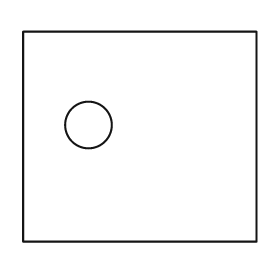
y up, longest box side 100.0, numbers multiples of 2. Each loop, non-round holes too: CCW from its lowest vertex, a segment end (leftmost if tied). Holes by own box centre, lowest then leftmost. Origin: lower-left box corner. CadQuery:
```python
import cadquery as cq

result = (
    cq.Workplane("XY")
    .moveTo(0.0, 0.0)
    .lineTo(100.0, 0.0)
    .lineTo(100.0, 90.0)
    .lineTo(0.0, 90.0)
    .close()
    .moveTo(28.0, 50.0)
    .circle(10.0)
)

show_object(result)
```